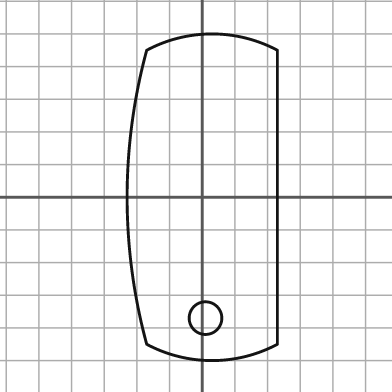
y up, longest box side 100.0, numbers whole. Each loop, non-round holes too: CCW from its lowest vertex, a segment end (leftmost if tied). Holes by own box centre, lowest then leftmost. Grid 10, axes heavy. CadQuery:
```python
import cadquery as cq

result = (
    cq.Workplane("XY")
    .moveTo(-17.0, -45.0)
    .threePointArc((3.0, -50.0), (23.0, -45.0))
    .lineTo(23.0, 45.0)
    .threePointArc((3.0, 50.0), (-17.0, 45.0))
    .threePointArc((-23.0, 0.0), (-17.0, -45.0))
    .close()
    .moveTo(1.0, -37.0)
    .circle(5.0)
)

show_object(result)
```